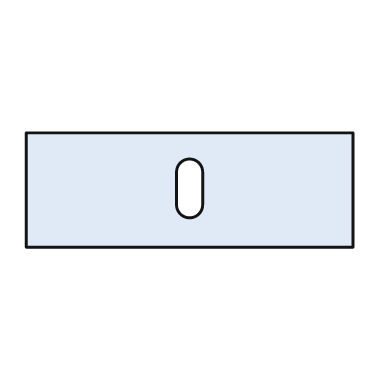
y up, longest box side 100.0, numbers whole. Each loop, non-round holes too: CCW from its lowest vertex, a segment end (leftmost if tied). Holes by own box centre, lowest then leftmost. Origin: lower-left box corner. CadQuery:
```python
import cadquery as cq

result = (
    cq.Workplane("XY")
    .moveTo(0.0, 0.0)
    .lineTo(100.0, 0.0)
    .lineTo(100.0, 35.0)
    .lineTo(0.0, 35.0)
    .close()
    .moveTo(46.0, 13.0)
    .threePointArc((50.0, 9.0), (54.0, 13.0))
    .lineTo(54.0, 23.0)
    .threePointArc((50.0, 27.0), (46.0, 23.0))
    .close()
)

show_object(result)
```